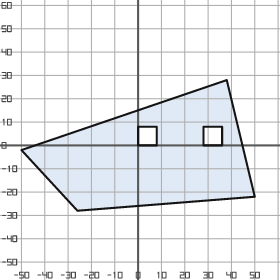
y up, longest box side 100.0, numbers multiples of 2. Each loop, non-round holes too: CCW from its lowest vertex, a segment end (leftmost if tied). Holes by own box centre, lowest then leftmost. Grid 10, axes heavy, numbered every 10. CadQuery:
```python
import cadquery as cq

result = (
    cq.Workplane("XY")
    .moveTo(-26.0, -28.0)
    .lineTo(50.0, -22.0)
    .lineTo(38.0, 28.0)
    .lineTo(-50.0, -2.0)
    .close()
    .moveTo(0.0, 0.0)
    .lineTo(8.0, 0.0)
    .lineTo(8.0, 8.0)
    .lineTo(0.0, 8.0)
    .close()
    .moveTo(28.0, 0.0)
    .lineTo(36.0, 0.0)
    .lineTo(36.0, 8.0)
    .lineTo(28.0, 8.0)
    .close()
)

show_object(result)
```